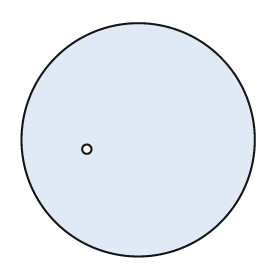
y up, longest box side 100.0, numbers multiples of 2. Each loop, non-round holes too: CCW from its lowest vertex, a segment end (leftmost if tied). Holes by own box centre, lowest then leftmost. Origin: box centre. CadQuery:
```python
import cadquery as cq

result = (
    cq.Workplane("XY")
    .moveTo(0.0, 0.0)
    .circle(50.0)
    .moveTo(-22.0, -4.0)
    .circle(2.0)
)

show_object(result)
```